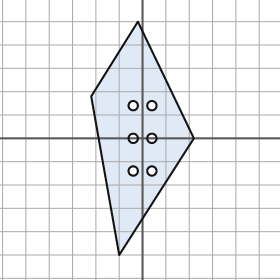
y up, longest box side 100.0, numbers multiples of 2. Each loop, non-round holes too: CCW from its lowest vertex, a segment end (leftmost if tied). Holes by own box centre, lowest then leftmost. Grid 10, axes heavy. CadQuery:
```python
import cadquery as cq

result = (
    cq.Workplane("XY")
    .moveTo(-10.0, -50.0)
    .lineTo(22.0, 0.0)
    .lineTo(-2.0, 50.0)
    .lineTo(-22.0, 18.0)
    .close()
    .moveTo(-4.0, -14.0)
    .circle(2.0)
    .moveTo(4.0, -14.0)
    .circle(2.0)
    .moveTo(-4.0, 0.0)
    .circle(2.0)
    .moveTo(4.0, 0.0)
    .circle(2.0)
    .moveTo(-4.0, 14.0)
    .circle(2.0)
    .moveTo(4.0, 14.0)
    .circle(2.0)
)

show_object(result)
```